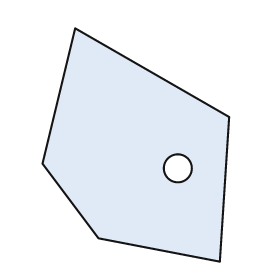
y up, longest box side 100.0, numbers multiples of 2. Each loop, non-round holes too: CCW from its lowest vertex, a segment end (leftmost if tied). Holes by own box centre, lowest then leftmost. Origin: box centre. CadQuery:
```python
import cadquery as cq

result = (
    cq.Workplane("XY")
    .moveTo(36.0, -50.0)
    .lineTo(40.0, 12.0)
    .lineTo(-26.0, 50.0)
    .lineTo(-40.0, -8.0)
    .lineTo(-16.0, -40.0)
    .close()
    .moveTo(18.0, -10.0)
    .circle(6.0)
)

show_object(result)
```